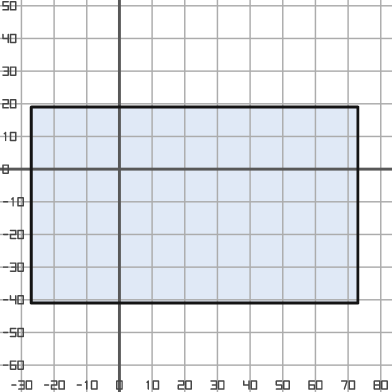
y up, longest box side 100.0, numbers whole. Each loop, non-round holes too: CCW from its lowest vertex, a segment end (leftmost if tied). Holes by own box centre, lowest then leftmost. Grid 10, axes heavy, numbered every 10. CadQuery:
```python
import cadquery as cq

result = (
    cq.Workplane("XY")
    .moveTo(-27.0, -41.0)
    .lineTo(73.0, -41.0)
    .lineTo(73.0, 19.0)
    .lineTo(-27.0, 19.0)
    .close()
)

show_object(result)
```